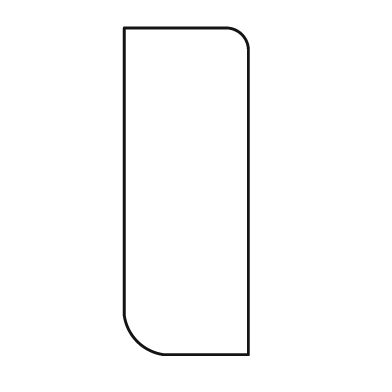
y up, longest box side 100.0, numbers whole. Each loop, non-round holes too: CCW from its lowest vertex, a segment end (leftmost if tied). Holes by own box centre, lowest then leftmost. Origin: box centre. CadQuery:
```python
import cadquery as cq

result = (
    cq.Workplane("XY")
    .moveTo(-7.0, -50.0)
    .lineTo(19.0, -50.0)
    .lineTo(19.0, 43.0)
    .threePointArc((17.0, 48.0), (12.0, 50.0))
    .lineTo(-19.0, 50.0)
    .lineTo(-19.0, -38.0)
    .threePointArc((-15.0, -46.0), (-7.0, -50.0))
    .close()
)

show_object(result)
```